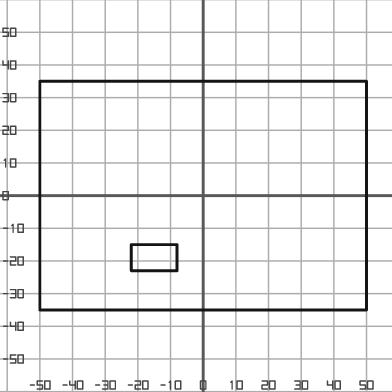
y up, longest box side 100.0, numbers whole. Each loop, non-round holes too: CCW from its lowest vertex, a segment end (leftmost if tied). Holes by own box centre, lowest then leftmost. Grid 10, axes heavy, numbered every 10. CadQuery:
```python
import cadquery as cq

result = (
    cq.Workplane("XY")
    .moveTo(-50.0, -35.0)
    .lineTo(50.0, -35.0)
    .lineTo(50.0, 35.0)
    .lineTo(-50.0, 35.0)
    .close()
    .moveTo(-22.0, -23.0)
    .lineTo(-8.0, -23.0)
    .lineTo(-8.0, -15.0)
    .lineTo(-22.0, -15.0)
    .close()
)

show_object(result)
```